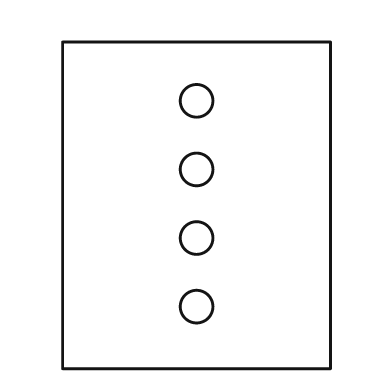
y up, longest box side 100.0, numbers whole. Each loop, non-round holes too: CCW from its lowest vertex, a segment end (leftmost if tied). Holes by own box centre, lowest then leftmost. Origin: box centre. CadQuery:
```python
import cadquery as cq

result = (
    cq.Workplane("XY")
    .moveTo(-41.0, -50.0)
    .lineTo(41.0, -50.0)
    .lineTo(41.0, 50.0)
    .lineTo(-41.0, 50.0)
    .close()
    .moveTo(0.0, -31.0)
    .circle(5.0)
    .moveTo(0.0, -10.0)
    .circle(5.0)
    .moveTo(0.0, 11.0)
    .circle(5.0)
    .moveTo(0.0, 32.0)
    .circle(5.0)
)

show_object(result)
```